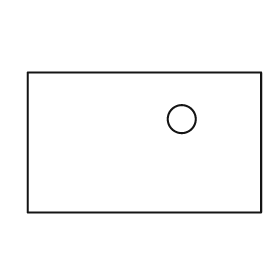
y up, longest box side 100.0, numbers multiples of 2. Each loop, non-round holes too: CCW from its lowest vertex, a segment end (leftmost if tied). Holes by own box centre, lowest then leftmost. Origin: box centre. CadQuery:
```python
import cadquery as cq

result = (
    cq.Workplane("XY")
    .moveTo(-50.0, -30.0)
    .lineTo(50.0, -30.0)
    .lineTo(50.0, 30.0)
    .lineTo(-50.0, 30.0)
    .close()
    .moveTo(16.0, 10.0)
    .circle(6.0)
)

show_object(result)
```